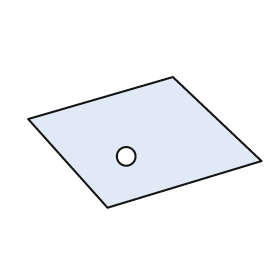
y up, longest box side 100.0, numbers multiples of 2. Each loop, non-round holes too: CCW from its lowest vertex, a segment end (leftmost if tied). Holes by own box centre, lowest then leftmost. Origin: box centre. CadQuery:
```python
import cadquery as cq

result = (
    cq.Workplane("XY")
    .moveTo(-16.0, -28.0)
    .lineTo(50.0, -8.0)
    .lineTo(12.0, 28.0)
    .lineTo(-50.0, 10.0)
    .close()
    .moveTo(-8.0, -6.0)
    .circle(4.0)
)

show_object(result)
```